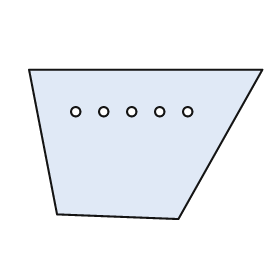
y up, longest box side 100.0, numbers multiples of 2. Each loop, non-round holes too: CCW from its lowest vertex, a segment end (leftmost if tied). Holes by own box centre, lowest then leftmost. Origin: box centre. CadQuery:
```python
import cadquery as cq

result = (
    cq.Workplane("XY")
    .moveTo(14.0, -32.0)
    .lineTo(50.0, 32.0)
    .lineTo(-50.0, 32.0)
    .lineTo(-38.0, -30.0)
    .close()
    .moveTo(-30.0, 14.0)
    .circle(2.0)
    .moveTo(-18.0, 14.0)
    .circle(2.0)
    .moveTo(-6.0, 14.0)
    .circle(2.0)
    .moveTo(6.0, 14.0)
    .circle(2.0)
    .moveTo(18.0, 14.0)
    .circle(2.0)
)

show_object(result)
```